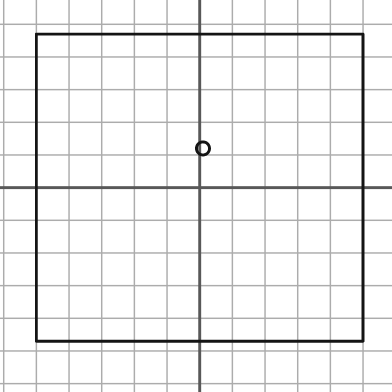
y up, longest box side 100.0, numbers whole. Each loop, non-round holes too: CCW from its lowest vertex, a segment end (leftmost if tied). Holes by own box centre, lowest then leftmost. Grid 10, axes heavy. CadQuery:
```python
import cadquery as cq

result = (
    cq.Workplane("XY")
    .moveTo(-50.0, -47.0)
    .lineTo(50.0, -47.0)
    .lineTo(50.0, 47.0)
    .lineTo(-50.0, 47.0)
    .close()
    .moveTo(1.0, 12.0)
    .circle(2.0)
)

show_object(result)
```